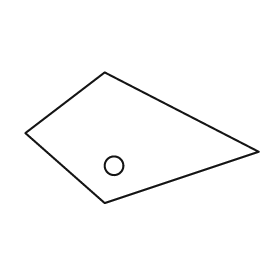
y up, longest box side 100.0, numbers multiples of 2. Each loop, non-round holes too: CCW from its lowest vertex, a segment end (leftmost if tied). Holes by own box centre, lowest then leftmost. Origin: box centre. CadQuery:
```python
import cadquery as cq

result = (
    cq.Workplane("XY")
    .moveTo(-16.0, -28.0)
    .lineTo(50.0, -6.0)
    .lineTo(-16.0, 28.0)
    .lineTo(-50.0, 2.0)
    .close()
    .moveTo(-12.0, -12.0)
    .circle(4.0)
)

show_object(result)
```